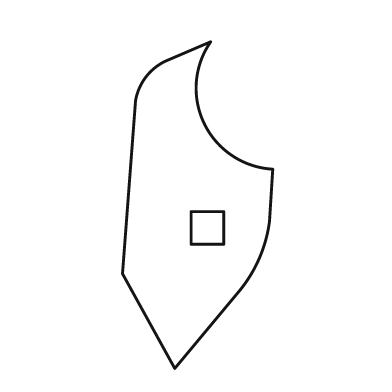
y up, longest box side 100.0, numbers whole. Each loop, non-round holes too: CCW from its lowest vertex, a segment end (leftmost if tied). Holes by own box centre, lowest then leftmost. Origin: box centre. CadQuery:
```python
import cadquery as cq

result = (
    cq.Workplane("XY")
    .moveTo(-7.0, -50.0)
    .lineTo(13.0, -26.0)
    .threePointArc((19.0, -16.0), (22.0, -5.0))
    .lineTo(23.0, 11.0)
    .threePointArc((2.0, 25.0), (4.0, 50.0))
    .lineTo(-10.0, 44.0)
    .threePointArc((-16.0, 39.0), (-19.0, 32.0))
    .lineTo(-23.0, -21.0)
    .close()
    .moveTo(-2.0, -12.0)
    .lineTo(8.0, -12.0)
    .lineTo(8.0, -2.0)
    .lineTo(-2.0, -2.0)
    .close()
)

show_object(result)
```